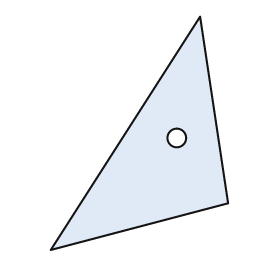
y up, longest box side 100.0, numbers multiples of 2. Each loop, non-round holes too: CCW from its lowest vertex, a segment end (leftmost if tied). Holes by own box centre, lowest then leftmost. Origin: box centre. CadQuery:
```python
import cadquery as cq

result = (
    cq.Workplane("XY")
    .moveTo(-38.0, -50.0)
    .lineTo(38.0, -30.0)
    .lineTo(26.0, 50.0)
    .close()
    .moveTo(16.0, -2.0)
    .circle(4.0)
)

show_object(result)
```